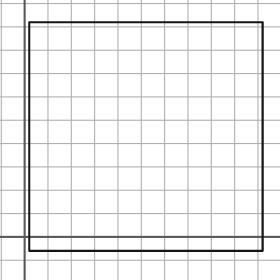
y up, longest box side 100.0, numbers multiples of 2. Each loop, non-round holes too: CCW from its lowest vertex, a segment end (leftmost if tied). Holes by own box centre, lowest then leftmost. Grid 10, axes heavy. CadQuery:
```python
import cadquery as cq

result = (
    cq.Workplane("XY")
    .moveTo(2.0, -6.0)
    .lineTo(102.0, -6.0)
    .lineTo(102.0, 92.0)
    .lineTo(2.0, 92.0)
    .close()
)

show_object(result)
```